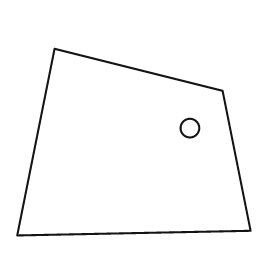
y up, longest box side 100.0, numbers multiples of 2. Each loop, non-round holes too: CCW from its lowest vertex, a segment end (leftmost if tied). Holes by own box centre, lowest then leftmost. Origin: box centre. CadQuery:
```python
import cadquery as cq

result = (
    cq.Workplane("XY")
    .moveTo(-50.0, -40.0)
    .lineTo(50.0, -38.0)
    .lineTo(38.0, 22.0)
    .lineTo(-34.0, 40.0)
    .close()
    .moveTo(24.0, 6.0)
    .circle(4.0)
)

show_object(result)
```